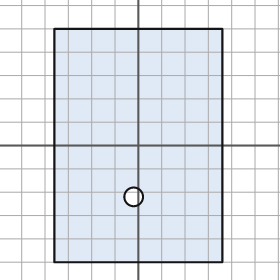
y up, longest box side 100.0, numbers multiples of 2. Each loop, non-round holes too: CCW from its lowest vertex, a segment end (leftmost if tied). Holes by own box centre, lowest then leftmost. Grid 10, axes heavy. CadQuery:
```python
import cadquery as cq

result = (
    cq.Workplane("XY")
    .moveTo(-36.0, -50.0)
    .lineTo(36.0, -50.0)
    .lineTo(36.0, 50.0)
    .lineTo(-36.0, 50.0)
    .close()
    .moveTo(-2.0, -22.0)
    .circle(4.0)
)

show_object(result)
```